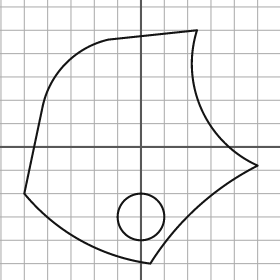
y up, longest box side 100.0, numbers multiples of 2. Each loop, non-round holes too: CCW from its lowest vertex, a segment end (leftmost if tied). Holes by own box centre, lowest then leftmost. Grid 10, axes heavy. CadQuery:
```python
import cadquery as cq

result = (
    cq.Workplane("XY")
    .moveTo(4.0, -50.0)
    .threePointArc((24.0, -26.0), (50.0, -8.0))
    .threePointArc((26.0, 16.0), (24.0, 50.0))
    .lineTo(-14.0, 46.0)
    .threePointArc((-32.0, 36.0), (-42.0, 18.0))
    .lineTo(-50.0, -20.0)
    .threePointArc((-26.0, -40.0), (4.0, -50.0))
    .close()
    .moveTo(0.0, -30.0)
    .circle(10.0)
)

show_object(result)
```